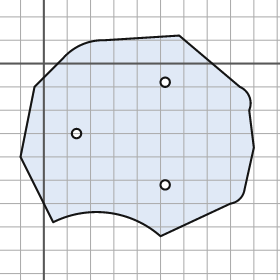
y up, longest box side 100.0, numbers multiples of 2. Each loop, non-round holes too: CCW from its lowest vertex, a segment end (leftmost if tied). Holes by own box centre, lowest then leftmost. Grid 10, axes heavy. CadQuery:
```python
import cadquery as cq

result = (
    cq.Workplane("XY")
    .moveTo(50.0, -74.0)
    .lineTo(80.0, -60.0)
    .threePointArc((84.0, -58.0), (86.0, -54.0))
    .lineTo(90.0, -36.0)
    .lineTo(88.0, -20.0)
    .threePointArc((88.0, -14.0), (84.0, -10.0))
    .lineTo(58.0, 12.0)
    .lineTo(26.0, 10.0)
    .threePointArc((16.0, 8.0), (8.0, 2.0))
    .lineTo(-4.0, -10.0)
    .lineTo(-10.0, -40.0)
    .lineTo(4.0, -68.0)
    .threePointArc((28.0, -64.0), (50.0, -74.0))
    .close()
    .moveTo(52.0, -52.0)
    .circle(2.0)
    .moveTo(14.0, -30.0)
    .circle(2.0)
    .moveTo(52.0, -8.0)
    .circle(2.0)
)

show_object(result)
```